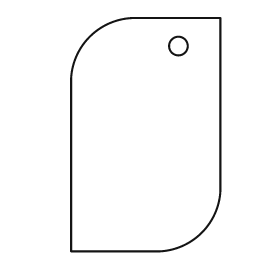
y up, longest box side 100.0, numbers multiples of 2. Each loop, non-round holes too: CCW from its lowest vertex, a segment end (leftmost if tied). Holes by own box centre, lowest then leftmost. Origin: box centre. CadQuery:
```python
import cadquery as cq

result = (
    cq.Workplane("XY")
    .moveTo(-32.0, -50.0)
    .lineTo(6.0, -50.0)
    .threePointArc((24.0, -42.0), (32.0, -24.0))
    .lineTo(32.0, 50.0)
    .lineTo(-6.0, 50.0)
    .threePointArc((-24.0, 42.0), (-32.0, 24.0))
    .close()
    .moveTo(14.0, 38.0)
    .circle(4.0)
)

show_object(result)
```